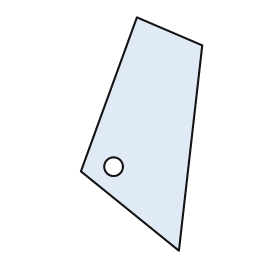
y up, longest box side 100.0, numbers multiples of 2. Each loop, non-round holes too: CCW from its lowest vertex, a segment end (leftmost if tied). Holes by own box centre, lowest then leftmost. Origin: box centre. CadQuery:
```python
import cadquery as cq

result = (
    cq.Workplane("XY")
    .moveTo(16.0, -50.0)
    .lineTo(26.0, 38.0)
    .lineTo(-2.0, 50.0)
    .lineTo(-26.0, -16.0)
    .close()
    .moveTo(-12.0, -14.0)
    .circle(4.0)
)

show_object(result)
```